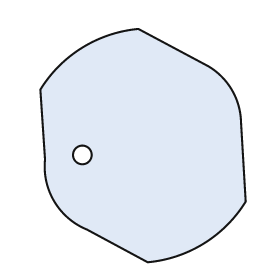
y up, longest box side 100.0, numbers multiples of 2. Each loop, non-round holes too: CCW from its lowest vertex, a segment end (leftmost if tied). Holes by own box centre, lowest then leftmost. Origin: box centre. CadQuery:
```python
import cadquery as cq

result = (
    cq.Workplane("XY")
    .moveTo(2.0, -50.0)
    .threePointArc((26.0, -42.0), (44.0, -24.0))
    .lineTo(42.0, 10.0)
    .threePointArc((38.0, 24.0), (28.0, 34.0))
    .lineTo(-2.0, 50.0)
    .threePointArc((-26.0, 42.0), (-44.0, 24.0))
    .lineTo(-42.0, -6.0)
    .threePointArc((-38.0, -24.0), (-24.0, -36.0))
    .close()
    .moveTo(-26.0, -4.0)
    .circle(4.0)
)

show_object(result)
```